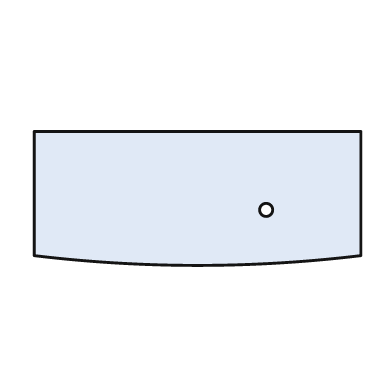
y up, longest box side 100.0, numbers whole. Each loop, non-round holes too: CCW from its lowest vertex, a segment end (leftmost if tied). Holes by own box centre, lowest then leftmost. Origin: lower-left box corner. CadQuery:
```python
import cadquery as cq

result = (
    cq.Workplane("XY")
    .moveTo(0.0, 3.0)
    .threePointArc((50.0, 0.0), (100.0, 3.0))
    .lineTo(100.0, 41.0)
    .lineTo(0.0, 41.0)
    .close()
    .moveTo(71.0, 17.0)
    .circle(2.0)
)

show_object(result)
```